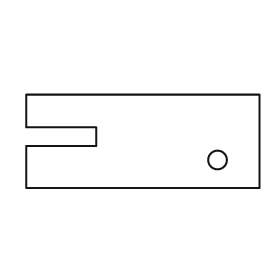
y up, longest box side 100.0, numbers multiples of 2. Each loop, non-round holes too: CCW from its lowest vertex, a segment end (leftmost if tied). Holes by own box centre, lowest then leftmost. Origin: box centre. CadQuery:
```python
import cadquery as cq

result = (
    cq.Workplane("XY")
    .moveTo(-50.0, -20.0)
    .lineTo(50.0, -20.0)
    .lineTo(50.0, 20.0)
    .lineTo(-50.0, 20.0)
    .lineTo(-50.0, 6.0)
    .lineTo(-20.0, 6.0)
    .lineTo(-20.0, -2.0)
    .lineTo(-50.0, -2.0)
    .close()
    .moveTo(32.0, -8.0)
    .circle(4.0)
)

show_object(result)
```